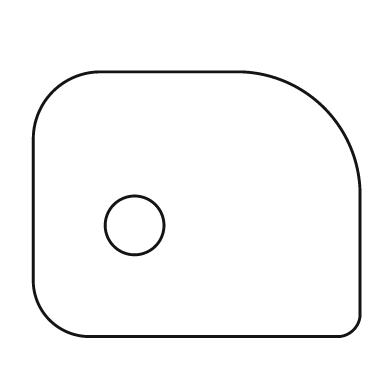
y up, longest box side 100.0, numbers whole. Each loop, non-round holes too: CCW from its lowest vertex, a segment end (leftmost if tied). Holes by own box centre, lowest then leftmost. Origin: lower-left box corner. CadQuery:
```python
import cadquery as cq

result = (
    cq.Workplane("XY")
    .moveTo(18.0, 0.0)
    .lineTo(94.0, 0.0)
    .threePointArc((98.0, 2.0), (100.0, 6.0))
    .lineTo(100.0, 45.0)
    .threePointArc((89.0, 70.0), (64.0, 81.0))
    .lineTo(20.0, 81.0)
    .threePointArc((6.0, 75.0), (0.0, 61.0))
    .lineTo(0.0, 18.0)
    .threePointArc((5.0, 5.0), (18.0, 0.0))
    .close()
    .moveTo(31.0, 34.0)
    .circle(9.0)
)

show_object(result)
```